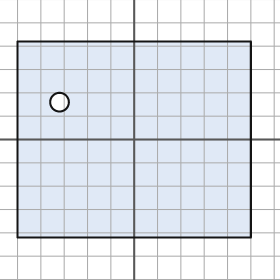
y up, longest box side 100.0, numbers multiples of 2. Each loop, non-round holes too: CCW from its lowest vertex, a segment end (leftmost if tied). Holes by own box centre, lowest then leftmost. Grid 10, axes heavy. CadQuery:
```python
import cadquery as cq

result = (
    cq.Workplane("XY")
    .moveTo(-50.0, -42.0)
    .lineTo(50.0, -42.0)
    .lineTo(50.0, 42.0)
    .lineTo(-50.0, 42.0)
    .close()
    .moveTo(-32.0, 16.0)
    .circle(4.0)
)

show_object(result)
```